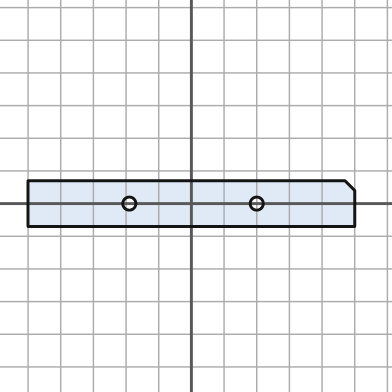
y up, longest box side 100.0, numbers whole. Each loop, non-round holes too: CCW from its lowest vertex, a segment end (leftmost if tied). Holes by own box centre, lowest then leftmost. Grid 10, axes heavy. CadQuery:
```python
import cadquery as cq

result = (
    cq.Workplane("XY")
    .moveTo(-50.0, -7.0)
    .lineTo(50.0, -7.0)
    .lineTo(50.0, 4.0)
    .lineTo(47.0, 7.0)
    .lineTo(-50.0, 7.0)
    .close()
    .moveTo(-19.0, 0.0)
    .circle(2.0)
    .moveTo(20.0, 0.0)
    .circle(2.0)
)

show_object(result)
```